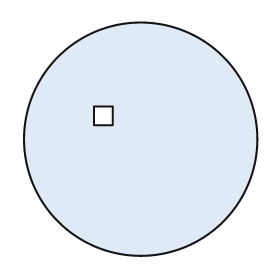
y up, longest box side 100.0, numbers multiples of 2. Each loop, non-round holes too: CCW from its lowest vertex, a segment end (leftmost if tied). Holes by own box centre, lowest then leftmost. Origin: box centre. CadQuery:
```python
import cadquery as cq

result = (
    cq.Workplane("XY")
    .moveTo(0.0, 0.0)
    .circle(50.0)
    .moveTo(-20.0, 6.0)
    .lineTo(-12.0, 6.0)
    .lineTo(-12.0, 14.0)
    .lineTo(-20.0, 14.0)
    .close()
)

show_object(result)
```